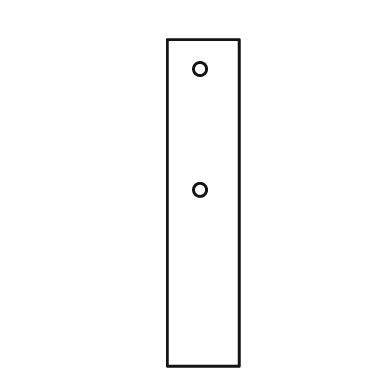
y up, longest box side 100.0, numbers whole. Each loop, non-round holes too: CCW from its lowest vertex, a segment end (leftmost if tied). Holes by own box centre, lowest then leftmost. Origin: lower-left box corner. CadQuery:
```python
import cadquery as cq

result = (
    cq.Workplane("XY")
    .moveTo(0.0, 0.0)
    .lineTo(22.0, 0.0)
    .lineTo(22.0, 100.0)
    .lineTo(0.0, 100.0)
    .close()
    .moveTo(10.0, 54.0)
    .circle(2.0)
    .moveTo(10.0, 91.0)
    .circle(2.0)
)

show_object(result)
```